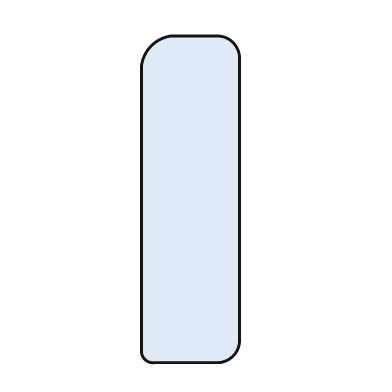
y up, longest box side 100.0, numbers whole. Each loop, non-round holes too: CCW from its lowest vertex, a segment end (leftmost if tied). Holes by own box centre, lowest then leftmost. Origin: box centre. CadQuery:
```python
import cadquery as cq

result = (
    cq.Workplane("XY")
    .moveTo(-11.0, -50.0)
    .lineTo(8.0, -50.0)
    .threePointArc((13.0, -48.0), (15.0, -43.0))
    .lineTo(15.0, 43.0)
    .threePointArc((13.0, 48.0), (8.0, 50.0))
    .lineTo(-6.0, 50.0)
    .threePointArc((-12.0, 47.0), (-15.0, 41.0))
    .lineTo(-15.0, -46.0)
    .threePointArc((-14.0, -49.0), (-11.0, -50.0))
    .close()
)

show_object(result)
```